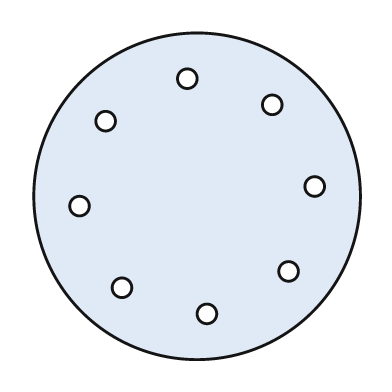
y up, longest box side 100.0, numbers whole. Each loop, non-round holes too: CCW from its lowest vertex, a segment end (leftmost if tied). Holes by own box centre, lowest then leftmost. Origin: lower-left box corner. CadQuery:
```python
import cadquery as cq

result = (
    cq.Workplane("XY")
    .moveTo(50.0, 50.0)
    .circle(50.0)
    .moveTo(53.0, 14.0)
    .circle(3.0)
    .moveTo(27.0, 22.0)
    .circle(3.0)
    .moveTo(78.0, 27.0)
    .circle(3.0)
    .moveTo(14.0, 47.0)
    .circle(3.0)
    .moveTo(86.0, 53.0)
    .circle(3.0)
    .moveTo(22.0, 73.0)
    .circle(3.0)
    .moveTo(73.0, 78.0)
    .circle(3.0)
    .moveTo(47.0, 86.0)
    .circle(3.0)
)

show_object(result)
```